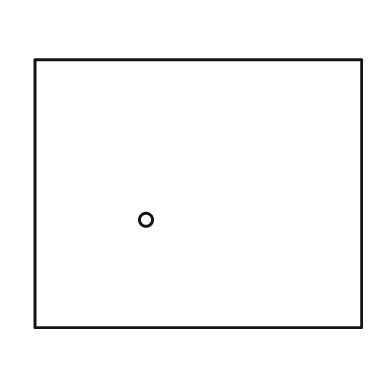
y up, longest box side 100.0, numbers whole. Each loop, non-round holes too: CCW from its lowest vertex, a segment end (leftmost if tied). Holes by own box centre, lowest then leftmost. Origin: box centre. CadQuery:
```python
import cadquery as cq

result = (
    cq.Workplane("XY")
    .moveTo(-50.0, -41.0)
    .lineTo(50.0, -41.0)
    .lineTo(50.0, 41.0)
    .lineTo(-50.0, 41.0)
    .close()
    .moveTo(-16.0, -8.0)
    .circle(2.0)
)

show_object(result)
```